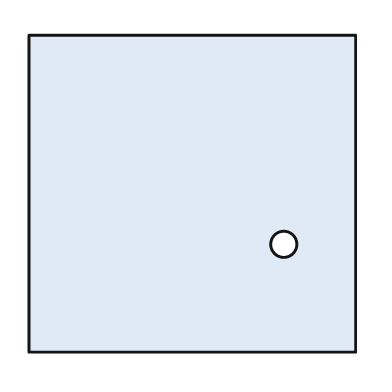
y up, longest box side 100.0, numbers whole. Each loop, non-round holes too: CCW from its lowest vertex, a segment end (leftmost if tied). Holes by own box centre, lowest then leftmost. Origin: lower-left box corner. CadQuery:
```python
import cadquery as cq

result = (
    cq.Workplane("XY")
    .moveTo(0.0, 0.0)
    .lineTo(100.0, 0.0)
    .lineTo(100.0, 97.0)
    .lineTo(0.0, 97.0)
    .close()
    .moveTo(78.0, 33.0)
    .circle(4.0)
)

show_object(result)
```